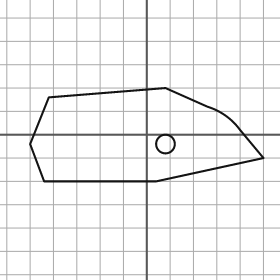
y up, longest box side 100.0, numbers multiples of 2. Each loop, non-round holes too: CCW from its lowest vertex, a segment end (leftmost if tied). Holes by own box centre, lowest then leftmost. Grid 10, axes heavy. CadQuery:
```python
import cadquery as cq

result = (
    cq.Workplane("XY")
    .moveTo(-44.0, -20.0)
    .lineTo(4.0, -20.0)
    .lineTo(50.0, -10.0)
    .lineTo(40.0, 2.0)
    .threePointArc((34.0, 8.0), (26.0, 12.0))
    .lineTo(8.0, 20.0)
    .lineTo(-42.0, 16.0)
    .lineTo(-50.0, -4.0)
    .close()
    .moveTo(8.0, -4.0)
    .circle(4.0)
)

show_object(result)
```